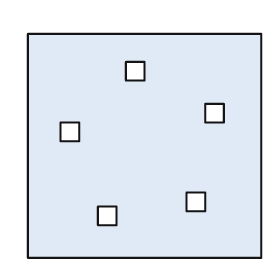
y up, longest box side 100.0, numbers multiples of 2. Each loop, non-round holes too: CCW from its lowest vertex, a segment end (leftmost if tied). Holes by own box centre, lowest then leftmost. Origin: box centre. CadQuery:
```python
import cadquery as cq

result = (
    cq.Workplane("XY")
    .moveTo(-50.0, -48.0)
    .lineTo(50.0, -48.0)
    .lineTo(50.0, 48.0)
    .lineTo(-50.0, 48.0)
    .close()
    .moveTo(-20.0, -34.0)
    .lineTo(-12.0, -34.0)
    .lineTo(-12.0, -26.0)
    .lineTo(-20.0, -26.0)
    .close()
    .moveTo(18.0, -28.0)
    .lineTo(26.0, -28.0)
    .lineTo(26.0, -20.0)
    .lineTo(18.0, -20.0)
    .close()
    .moveTo(-36.0, 2.0)
    .lineTo(-28.0, 2.0)
    .lineTo(-28.0, 10.0)
    .lineTo(-36.0, 10.0)
    .close()
    .moveTo(26.0, 10.0)
    .lineTo(34.0, 10.0)
    .lineTo(34.0, 18.0)
    .lineTo(26.0, 18.0)
    .close()
    .moveTo(-8.0, 28.0)
    .lineTo(0.0, 28.0)
    .lineTo(0.0, 36.0)
    .lineTo(-8.0, 36.0)
    .close()
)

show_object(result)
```